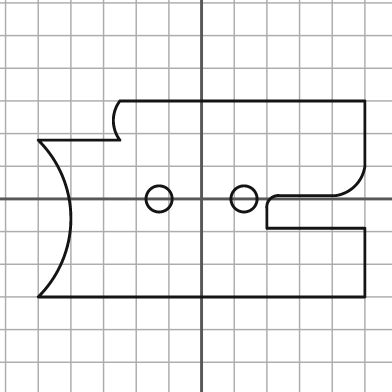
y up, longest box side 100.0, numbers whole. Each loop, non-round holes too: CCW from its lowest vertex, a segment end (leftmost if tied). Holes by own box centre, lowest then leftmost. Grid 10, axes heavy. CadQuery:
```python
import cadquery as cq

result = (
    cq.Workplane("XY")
    .moveTo(-50.0, -30.0)
    .lineTo(50.0, -30.0)
    .lineTo(50.0, -9.0)
    .lineTo(20.0, -9.0)
    .lineTo(20.0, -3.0)
    .threePointArc((21.0, 0.0), (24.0, 1.0))
    .lineTo(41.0, 1.0)
    .threePointArc((47.0, 4.0), (50.0, 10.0))
    .lineTo(50.0, 30.0)
    .lineTo(-25.0, 30.0)
    .threePointArc((-27.0, 24.0), (-25.0, 18.0))
    .lineTo(-50.0, 18.0)
    .threePointArc((-40.0, -6.0), (-50.0, -30.0))
    .close()
    .moveTo(-13.0, 0.0)
    .circle(4.0)
    .moveTo(13.0, 0.0)
    .circle(4.0)
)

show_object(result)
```